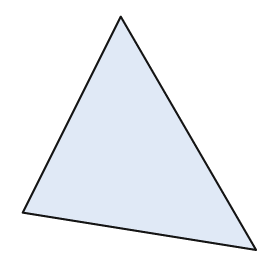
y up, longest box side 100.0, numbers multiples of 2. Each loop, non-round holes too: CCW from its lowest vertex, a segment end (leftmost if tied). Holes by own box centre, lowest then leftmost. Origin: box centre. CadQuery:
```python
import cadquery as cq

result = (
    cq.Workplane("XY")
    .moveTo(50.0, -50.0)
    .lineTo(-8.0, 50.0)
    .lineTo(-50.0, -34.0)
    .close()
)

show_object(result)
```